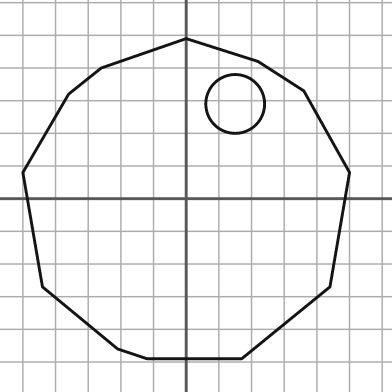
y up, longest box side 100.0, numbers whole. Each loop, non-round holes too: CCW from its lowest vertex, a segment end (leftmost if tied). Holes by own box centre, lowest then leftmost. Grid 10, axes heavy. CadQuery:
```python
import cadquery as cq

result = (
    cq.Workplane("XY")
    .moveTo(-12.0, -49.0)
    .lineTo(17.0, -49.0)
    .lineTo(44.0, -27.0)
    .lineTo(50.0, 8.0)
    .lineTo(36.0, 33.0)
    .lineTo(22.0, 42.0)
    .lineTo(0.0, 49.0)
    .lineTo(-26.0, 40.0)
    .lineTo(-36.0, 32.0)
    .lineTo(-50.0, 8.0)
    .lineTo(-44.0, -27.0)
    .lineTo(-21.0, -46.0)
    .close()
    .moveTo(15.0, 29.0)
    .circle(9.0)
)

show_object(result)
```